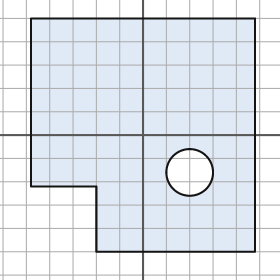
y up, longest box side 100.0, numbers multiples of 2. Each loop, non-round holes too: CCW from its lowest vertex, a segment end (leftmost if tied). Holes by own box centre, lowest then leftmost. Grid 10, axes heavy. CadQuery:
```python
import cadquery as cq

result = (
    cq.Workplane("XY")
    .moveTo(-20.0, -50.0)
    .lineTo(48.0, -50.0)
    .lineTo(48.0, 50.0)
    .lineTo(-48.0, 50.0)
    .lineTo(-48.0, -22.0)
    .lineTo(-20.0, -22.0)
    .close()
    .moveTo(20.0, -16.0)
    .circle(10.0)
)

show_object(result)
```